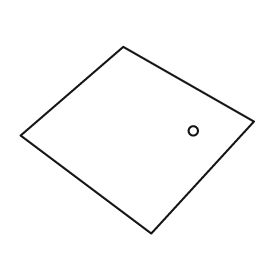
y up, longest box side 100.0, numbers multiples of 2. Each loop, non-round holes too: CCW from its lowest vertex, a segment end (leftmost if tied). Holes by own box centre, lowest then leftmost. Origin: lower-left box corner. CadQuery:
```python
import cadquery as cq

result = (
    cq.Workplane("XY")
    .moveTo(56.0, 0.0)
    .lineTo(100.0, 48.0)
    .lineTo(44.0, 80.0)
    .lineTo(0.0, 42.0)
    .close()
    .moveTo(74.0, 44.0)
    .circle(2.0)
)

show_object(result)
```